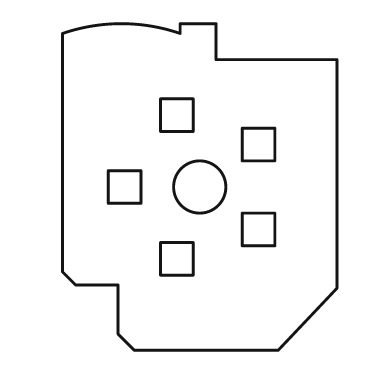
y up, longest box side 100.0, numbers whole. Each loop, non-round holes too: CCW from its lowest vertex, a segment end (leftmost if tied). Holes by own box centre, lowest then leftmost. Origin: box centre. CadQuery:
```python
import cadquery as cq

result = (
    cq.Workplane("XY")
    .moveTo(-20.0, -50.0)
    .lineTo(24.0, -50.0)
    .lineTo(42.0, -31.0)
    .lineTo(42.0, 39.0)
    .lineTo(5.0, 39.0)
    .lineTo(5.0, 50.0)
    .lineTo(-6.0, 50.0)
    .lineTo(-6.0, 47.0)
    .threePointArc((-24.0, 50.0), (-42.0, 47.0))
    .lineTo(-42.0, -26.0)
    .lineTo(-38.0, -30.0)
    .lineTo(-25.0, -30.0)
    .lineTo(-25.0, -45.0)
    .close()
    .moveTo(-12.0, -27.0)
    .lineTo(-2.0, -27.0)
    .lineTo(-2.0, -17.0)
    .lineTo(-12.0, -17.0)
    .close()
    .moveTo(13.0, -18.0)
    .lineTo(23.0, -18.0)
    .lineTo(23.0, -8.0)
    .lineTo(13.0, -8.0)
    .close()
    .moveTo(-28.0, -5.0)
    .lineTo(-18.0, -5.0)
    .lineTo(-18.0, 5.0)
    .lineTo(-28.0, 5.0)
    .close()
    .moveTo(0.0, 0.0)
    .circle(8.0)
    .moveTo(13.0, 8.0)
    .lineTo(23.0, 8.0)
    .lineTo(23.0, 18.0)
    .lineTo(13.0, 18.0)
    .close()
    .moveTo(-12.0, 17.0)
    .lineTo(-2.0, 17.0)
    .lineTo(-2.0, 27.0)
    .lineTo(-12.0, 27.0)
    .close()
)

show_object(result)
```